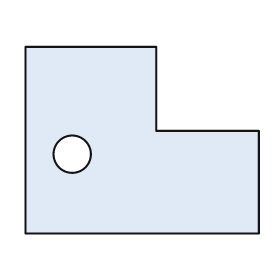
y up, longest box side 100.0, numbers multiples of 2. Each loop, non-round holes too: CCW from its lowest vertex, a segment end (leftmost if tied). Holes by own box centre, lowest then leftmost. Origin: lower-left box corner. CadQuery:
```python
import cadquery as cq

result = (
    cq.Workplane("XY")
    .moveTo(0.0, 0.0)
    .lineTo(100.0, 0.0)
    .lineTo(100.0, 44.0)
    .lineTo(56.0, 44.0)
    .lineTo(56.0, 80.0)
    .lineTo(0.0, 80.0)
    .close()
    .moveTo(20.0, 34.0)
    .circle(8.0)
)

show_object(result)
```